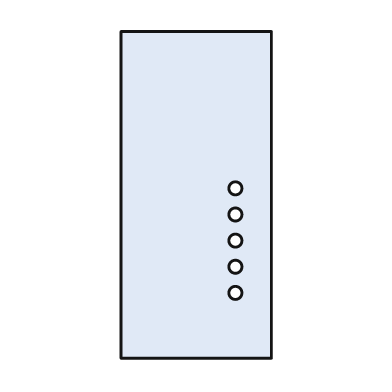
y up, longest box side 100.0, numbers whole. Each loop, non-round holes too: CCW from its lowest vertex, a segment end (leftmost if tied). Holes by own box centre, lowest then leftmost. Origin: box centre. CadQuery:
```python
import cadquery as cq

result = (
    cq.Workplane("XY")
    .moveTo(-23.0, -50.0)
    .lineTo(23.0, -50.0)
    .lineTo(23.0, 50.0)
    .lineTo(-23.0, 50.0)
    .close()
    .moveTo(12.0, -30.0)
    .circle(2.0)
    .moveTo(12.0, -22.0)
    .circle(2.0)
    .moveTo(12.0, -14.0)
    .circle(2.0)
    .moveTo(12.0, -6.0)
    .circle(2.0)
    .moveTo(12.0, 2.0)
    .circle(2.0)
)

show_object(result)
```